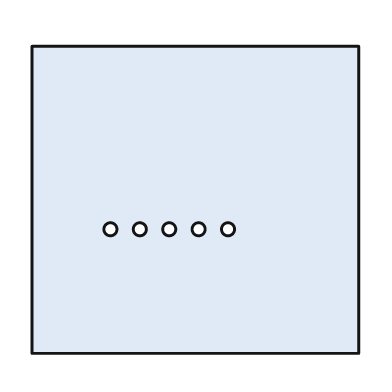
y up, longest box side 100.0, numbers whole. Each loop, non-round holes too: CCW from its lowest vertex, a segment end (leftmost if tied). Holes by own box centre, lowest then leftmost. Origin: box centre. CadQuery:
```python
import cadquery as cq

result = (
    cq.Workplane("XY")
    .moveTo(-50.0, -47.0)
    .lineTo(50.0, -47.0)
    .lineTo(50.0, 47.0)
    .lineTo(-50.0, 47.0)
    .close()
    .moveTo(-26.0, -9.0)
    .circle(2.0)
    .moveTo(-17.0, -9.0)
    .circle(2.0)
    .moveTo(-8.0, -9.0)
    .circle(2.0)
    .moveTo(1.0, -9.0)
    .circle(2.0)
    .moveTo(10.0, -9.0)
    .circle(2.0)
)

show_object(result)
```